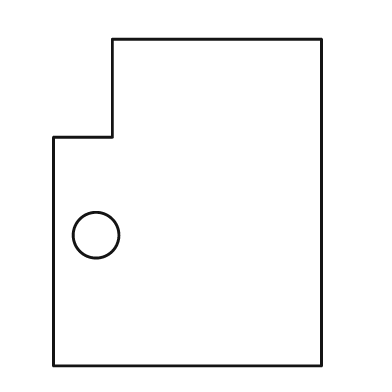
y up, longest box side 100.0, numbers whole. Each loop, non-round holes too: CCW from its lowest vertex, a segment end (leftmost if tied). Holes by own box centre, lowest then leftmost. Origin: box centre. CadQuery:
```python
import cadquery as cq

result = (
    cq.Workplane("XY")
    .moveTo(-41.0, -50.0)
    .lineTo(41.0, -50.0)
    .lineTo(41.0, 50.0)
    .lineTo(-23.0, 50.0)
    .lineTo(-23.0, 20.0)
    .lineTo(-41.0, 20.0)
    .close()
    .moveTo(-28.0, -10.0)
    .circle(7.0)
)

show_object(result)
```